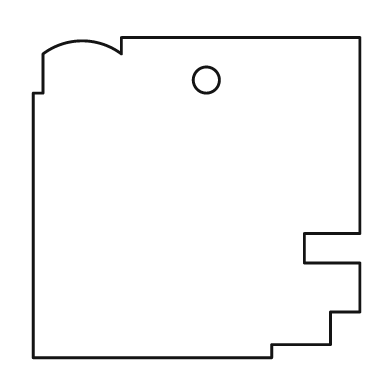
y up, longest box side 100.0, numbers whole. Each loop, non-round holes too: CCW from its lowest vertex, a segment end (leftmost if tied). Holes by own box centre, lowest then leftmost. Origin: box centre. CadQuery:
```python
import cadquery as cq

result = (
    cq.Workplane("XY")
    .moveTo(-50.0, -49.0)
    .lineTo(23.0, -49.0)
    .lineTo(23.0, -45.0)
    .lineTo(41.0, -45.0)
    .lineTo(41.0, -35.0)
    .lineTo(50.0, -35.0)
    .lineTo(50.0, -20.0)
    .lineTo(33.0, -20.0)
    .lineTo(33.0, -11.0)
    .lineTo(50.0, -11.0)
    .lineTo(50.0, 49.0)
    .lineTo(-23.0, 49.0)
    .lineTo(-23.0, 44.0)
    .threePointArc((-35.0, 48.0), (-47.0, 44.0))
    .lineTo(-47.0, 32.0)
    .lineTo(-50.0, 32.0)
    .close()
    .moveTo(3.0, 36.0)
    .circle(4.0)
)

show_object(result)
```